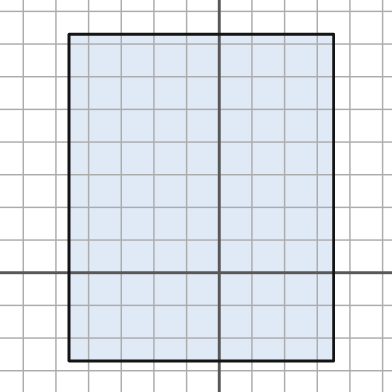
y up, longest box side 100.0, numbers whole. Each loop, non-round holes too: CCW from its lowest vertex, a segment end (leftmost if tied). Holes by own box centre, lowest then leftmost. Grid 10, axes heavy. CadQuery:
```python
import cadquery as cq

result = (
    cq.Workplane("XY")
    .moveTo(-46.0, -27.0)
    .lineTo(35.0, -27.0)
    .lineTo(35.0, 73.0)
    .lineTo(-46.0, 73.0)
    .close()
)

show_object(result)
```